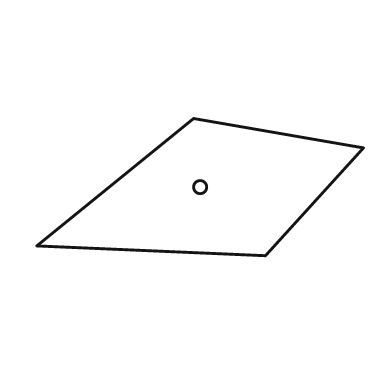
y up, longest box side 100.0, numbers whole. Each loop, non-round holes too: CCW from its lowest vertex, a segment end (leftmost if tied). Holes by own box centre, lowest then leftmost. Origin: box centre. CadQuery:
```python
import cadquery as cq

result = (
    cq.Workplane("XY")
    .moveTo(20.0, -21.0)
    .lineTo(50.0, 12.0)
    .lineTo(-2.0, 21.0)
    .lineTo(-50.0, -18.0)
    .close()
    .moveTo(0.0, 0.0)
    .circle(2.0)
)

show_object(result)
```